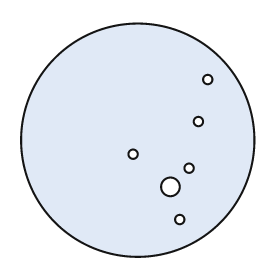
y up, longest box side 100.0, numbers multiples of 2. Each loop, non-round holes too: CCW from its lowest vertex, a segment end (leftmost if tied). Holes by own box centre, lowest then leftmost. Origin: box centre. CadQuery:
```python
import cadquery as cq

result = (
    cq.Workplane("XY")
    .moveTo(0.0, 0.0)
    .circle(50.0)
    .moveTo(18.0, -34.0)
    .circle(2.0)
    .moveTo(14.0, -20.0)
    .circle(4.0)
    .moveTo(22.0, -12.0)
    .circle(2.0)
    .moveTo(-2.0, -6.0)
    .circle(2.0)
    .moveTo(26.0, 8.0)
    .circle(2.0)
    .moveTo(30.0, 26.0)
    .circle(2.0)
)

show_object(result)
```